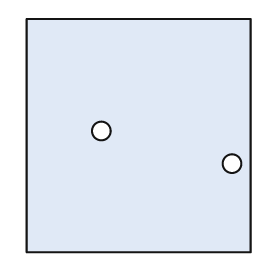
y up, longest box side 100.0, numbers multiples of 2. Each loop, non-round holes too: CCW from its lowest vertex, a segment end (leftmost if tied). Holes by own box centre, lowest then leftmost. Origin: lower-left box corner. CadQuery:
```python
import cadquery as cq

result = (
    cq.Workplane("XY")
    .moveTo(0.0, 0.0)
    .lineTo(96.0, 0.0)
    .lineTo(96.0, 100.0)
    .lineTo(0.0, 100.0)
    .close()
    .moveTo(88.0, 38.0)
    .circle(4.0)
    .moveTo(32.0, 52.0)
    .circle(4.0)
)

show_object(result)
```